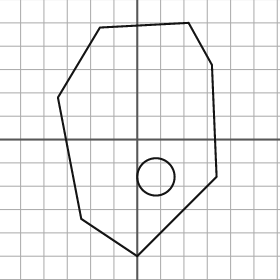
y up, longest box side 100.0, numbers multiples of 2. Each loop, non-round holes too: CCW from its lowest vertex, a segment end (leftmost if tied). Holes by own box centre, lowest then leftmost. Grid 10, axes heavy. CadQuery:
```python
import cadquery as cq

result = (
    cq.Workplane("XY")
    .moveTo(0.0, -50.0)
    .lineTo(34.0, -16.0)
    .lineTo(32.0, 32.0)
    .lineTo(22.0, 50.0)
    .lineTo(-16.0, 48.0)
    .lineTo(-34.0, 18.0)
    .lineTo(-24.0, -34.0)
    .close()
    .moveTo(8.0, -16.0)
    .circle(8.0)
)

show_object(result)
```